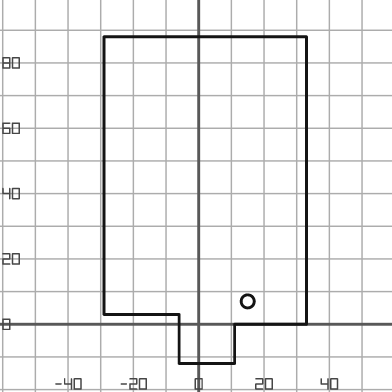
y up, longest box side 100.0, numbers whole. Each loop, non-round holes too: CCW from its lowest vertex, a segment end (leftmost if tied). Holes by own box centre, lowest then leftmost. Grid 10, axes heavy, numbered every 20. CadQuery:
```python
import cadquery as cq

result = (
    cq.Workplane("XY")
    .moveTo(-6.0, -12.0)
    .lineTo(11.0, -12.0)
    .lineTo(11.0, 0.0)
    .lineTo(33.0, 0.0)
    .lineTo(33.0, 88.0)
    .lineTo(-29.0, 88.0)
    .lineTo(-29.0, 3.0)
    .lineTo(-6.0, 3.0)
    .close()
    .moveTo(15.0, 7.0)
    .circle(2.0)
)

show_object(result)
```